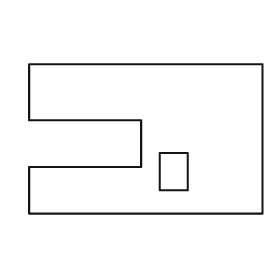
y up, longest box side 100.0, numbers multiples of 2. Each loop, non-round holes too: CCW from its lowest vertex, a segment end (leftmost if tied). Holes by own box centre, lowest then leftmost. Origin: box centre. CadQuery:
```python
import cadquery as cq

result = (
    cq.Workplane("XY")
    .moveTo(-50.0, -32.0)
    .lineTo(50.0, -32.0)
    .lineTo(50.0, 32.0)
    .lineTo(-50.0, 32.0)
    .lineTo(-50.0, 8.0)
    .lineTo(-2.0, 8.0)
    .lineTo(-2.0, -12.0)
    .lineTo(-50.0, -12.0)
    .close()
    .moveTo(6.0, -22.0)
    .lineTo(18.0, -22.0)
    .lineTo(18.0, -6.0)
    .lineTo(6.0, -6.0)
    .close()
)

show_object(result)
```